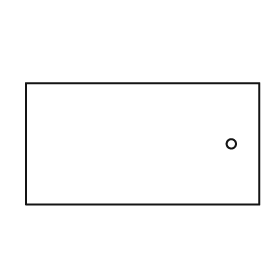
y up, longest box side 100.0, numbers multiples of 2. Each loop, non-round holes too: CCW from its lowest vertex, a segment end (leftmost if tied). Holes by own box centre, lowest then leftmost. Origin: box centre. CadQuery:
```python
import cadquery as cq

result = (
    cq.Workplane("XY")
    .moveTo(-50.0, -26.0)
    .lineTo(50.0, -26.0)
    .lineTo(50.0, 26.0)
    .lineTo(-50.0, 26.0)
    .close()
    .moveTo(38.0, 0.0)
    .circle(2.0)
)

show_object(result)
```